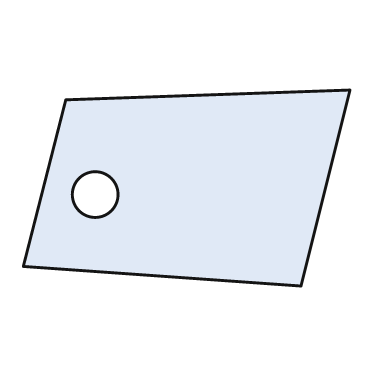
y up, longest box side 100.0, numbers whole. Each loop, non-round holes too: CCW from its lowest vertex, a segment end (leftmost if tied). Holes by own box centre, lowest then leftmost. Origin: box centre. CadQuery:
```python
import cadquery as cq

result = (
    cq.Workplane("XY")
    .moveTo(35.0, -30.0)
    .lineTo(50.0, 30.0)
    .lineTo(-37.0, 27.0)
    .lineTo(-50.0, -24.0)
    .close()
    .moveTo(-28.0, -2.0)
    .circle(7.0)
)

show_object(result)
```